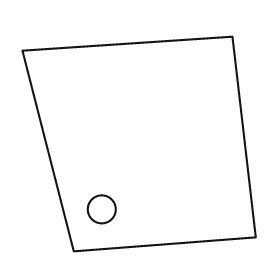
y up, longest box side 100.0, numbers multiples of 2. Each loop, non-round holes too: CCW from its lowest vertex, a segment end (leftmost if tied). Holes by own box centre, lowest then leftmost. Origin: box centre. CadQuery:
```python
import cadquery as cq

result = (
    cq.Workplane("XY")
    .moveTo(-28.0, -46.0)
    .lineTo(50.0, -40.0)
    .lineTo(40.0, 46.0)
    .lineTo(-50.0, 40.0)
    .close()
    .moveTo(-16.0, -28.0)
    .circle(6.0)
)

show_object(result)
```